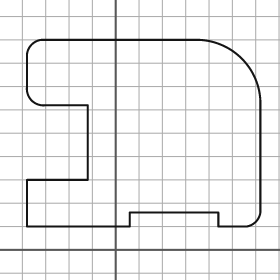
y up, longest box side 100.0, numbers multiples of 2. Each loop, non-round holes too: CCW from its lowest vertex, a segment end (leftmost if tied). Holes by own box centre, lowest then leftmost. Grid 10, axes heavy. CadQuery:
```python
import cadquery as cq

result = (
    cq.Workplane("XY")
    .moveTo(-38.0, 10.0)
    .lineTo(6.0, 10.0)
    .lineTo(6.0, 16.0)
    .lineTo(44.0, 16.0)
    .lineTo(44.0, 10.0)
    .lineTo(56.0, 10.0)
    .threePointArc((60.0, 12.0), (62.0, 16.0))
    .lineTo(62.0, 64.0)
    .threePointArc((54.0, 82.0), (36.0, 90.0))
    .lineTo(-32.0, 90.0)
    .threePointArc((-36.0, 88.0), (-38.0, 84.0))
    .lineTo(-38.0, 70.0)
    .threePointArc((-36.0, 64.0), (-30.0, 62.0))
    .lineTo(-12.0, 62.0)
    .lineTo(-12.0, 30.0)
    .lineTo(-38.0, 30.0)
    .close()
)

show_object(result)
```